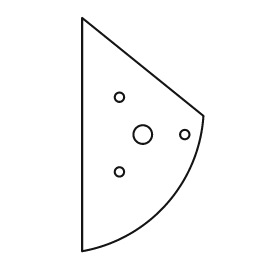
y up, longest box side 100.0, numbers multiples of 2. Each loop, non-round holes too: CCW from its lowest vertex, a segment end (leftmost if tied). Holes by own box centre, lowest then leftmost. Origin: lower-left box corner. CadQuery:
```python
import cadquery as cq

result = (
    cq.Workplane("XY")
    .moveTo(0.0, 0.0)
    .threePointArc((36.0, 20.0), (52.0, 58.0))
    .lineTo(0.0, 100.0)
    .close()
    .moveTo(16.0, 34.0)
    .circle(2.0)
    .moveTo(26.0, 50.0)
    .circle(4.0)
    .moveTo(44.0, 50.0)
    .circle(2.0)
    .moveTo(16.0, 66.0)
    .circle(2.0)
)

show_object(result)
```